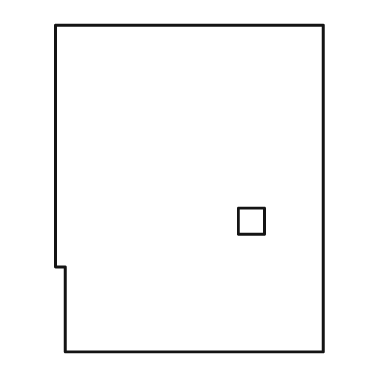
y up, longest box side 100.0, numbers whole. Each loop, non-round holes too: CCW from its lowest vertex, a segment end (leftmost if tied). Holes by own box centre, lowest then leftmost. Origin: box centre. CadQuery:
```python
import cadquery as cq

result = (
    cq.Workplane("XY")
    .moveTo(-38.0, -50.0)
    .lineTo(41.0, -50.0)
    .lineTo(41.0, 50.0)
    .lineTo(-41.0, 50.0)
    .lineTo(-41.0, -24.0)
    .lineTo(-38.0, -24.0)
    .close()
    .moveTo(15.0, -14.0)
    .lineTo(23.0, -14.0)
    .lineTo(23.0, -6.0)
    .lineTo(15.0, -6.0)
    .close()
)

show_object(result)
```